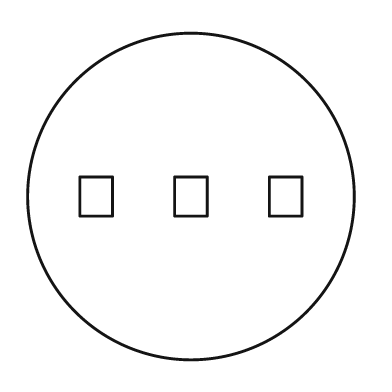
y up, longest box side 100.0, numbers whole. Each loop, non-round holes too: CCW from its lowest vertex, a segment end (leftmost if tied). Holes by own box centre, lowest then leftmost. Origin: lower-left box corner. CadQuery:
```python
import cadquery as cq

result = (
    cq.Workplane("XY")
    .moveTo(50.0, 50.0)
    .circle(50.0)
    .moveTo(16.0, 44.0)
    .lineTo(26.0, 44.0)
    .lineTo(26.0, 56.0)
    .lineTo(16.0, 56.0)
    .close()
    .moveTo(45.0, 44.0)
    .lineTo(55.0, 44.0)
    .lineTo(55.0, 56.0)
    .lineTo(45.0, 56.0)
    .close()
    .moveTo(74.0, 44.0)
    .lineTo(84.0, 44.0)
    .lineTo(84.0, 56.0)
    .lineTo(74.0, 56.0)
    .close()
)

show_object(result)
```